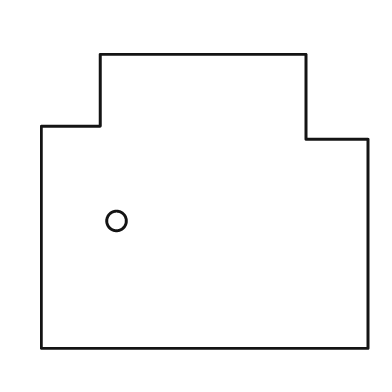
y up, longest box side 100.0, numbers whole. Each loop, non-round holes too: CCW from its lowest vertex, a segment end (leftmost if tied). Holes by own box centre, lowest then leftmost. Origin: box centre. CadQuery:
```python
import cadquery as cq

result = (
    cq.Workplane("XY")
    .moveTo(-50.0, -45.0)
    .lineTo(50.0, -45.0)
    .lineTo(50.0, 19.0)
    .lineTo(31.0, 19.0)
    .lineTo(31.0, 45.0)
    .lineTo(-32.0, 45.0)
    .lineTo(-32.0, 23.0)
    .lineTo(-50.0, 23.0)
    .close()
    .moveTo(-27.0, -6.0)
    .circle(3.0)
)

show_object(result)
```